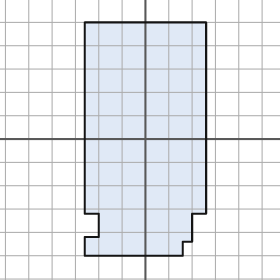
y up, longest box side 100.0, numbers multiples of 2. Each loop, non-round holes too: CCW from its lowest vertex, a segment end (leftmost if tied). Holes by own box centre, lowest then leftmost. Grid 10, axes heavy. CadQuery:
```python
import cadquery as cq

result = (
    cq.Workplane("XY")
    .moveTo(-26.0, -50.0)
    .lineTo(16.0, -50.0)
    .lineTo(16.0, -44.0)
    .lineTo(20.0, -44.0)
    .lineTo(20.0, -32.0)
    .lineTo(26.0, -32.0)
    .lineTo(26.0, 50.0)
    .lineTo(-26.0, 50.0)
    .lineTo(-26.0, -32.0)
    .lineTo(-20.0, -32.0)
    .lineTo(-20.0, -42.0)
    .lineTo(-26.0, -42.0)
    .close()
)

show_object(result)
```